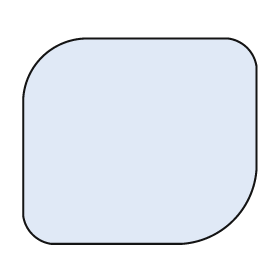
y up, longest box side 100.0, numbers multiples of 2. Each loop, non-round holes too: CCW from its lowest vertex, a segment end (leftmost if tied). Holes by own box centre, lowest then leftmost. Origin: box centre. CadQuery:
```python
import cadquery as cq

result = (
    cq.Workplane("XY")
    .moveTo(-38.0, -44.0)
    .lineTo(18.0, -44.0)
    .threePointArc((40.0, -34.0), (50.0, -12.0))
    .lineTo(50.0, 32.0)
    .threePointArc((46.0, 40.0), (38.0, 44.0))
    .lineTo(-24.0, 44.0)
    .threePointArc((-42.0, 36.0), (-50.0, 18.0))
    .lineTo(-50.0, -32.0)
    .threePointArc((-46.0, -40.0), (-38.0, -44.0))
    .close()
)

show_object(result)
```